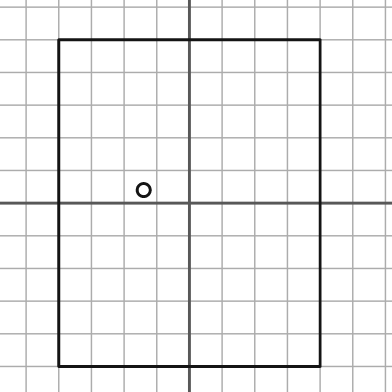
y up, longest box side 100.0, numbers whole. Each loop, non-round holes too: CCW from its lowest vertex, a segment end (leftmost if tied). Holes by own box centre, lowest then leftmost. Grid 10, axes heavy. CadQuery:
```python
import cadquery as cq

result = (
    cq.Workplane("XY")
    .moveTo(-40.0, -50.0)
    .lineTo(40.0, -50.0)
    .lineTo(40.0, 50.0)
    .lineTo(-40.0, 50.0)
    .close()
    .moveTo(-14.0, 4.0)
    .circle(2.0)
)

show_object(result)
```